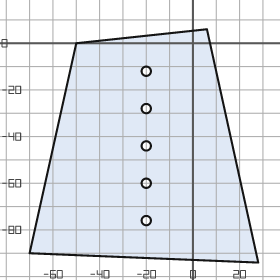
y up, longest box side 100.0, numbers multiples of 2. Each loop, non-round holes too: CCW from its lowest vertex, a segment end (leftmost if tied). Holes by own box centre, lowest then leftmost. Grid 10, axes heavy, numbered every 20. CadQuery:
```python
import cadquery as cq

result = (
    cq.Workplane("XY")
    .moveTo(28.0, -94.0)
    .lineTo(6.0, 6.0)
    .lineTo(-50.0, 0.0)
    .lineTo(-70.0, -90.0)
    .close()
    .moveTo(-20.0, -76.0)
    .circle(2.0)
    .moveTo(-20.0, -60.0)
    .circle(2.0)
    .moveTo(-20.0, -44.0)
    .circle(2.0)
    .moveTo(-20.0, -28.0)
    .circle(2.0)
    .moveTo(-20.0, -12.0)
    .circle(2.0)
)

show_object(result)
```